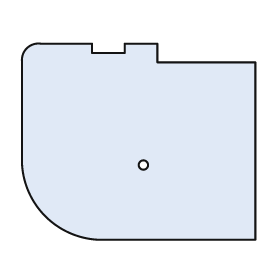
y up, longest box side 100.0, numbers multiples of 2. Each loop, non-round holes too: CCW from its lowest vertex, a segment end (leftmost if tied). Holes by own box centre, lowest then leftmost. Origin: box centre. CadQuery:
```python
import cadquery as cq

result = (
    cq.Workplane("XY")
    .moveTo(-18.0, -42.0)
    .lineTo(50.0, -42.0)
    .lineTo(50.0, 34.0)
    .lineTo(8.0, 34.0)
    .lineTo(8.0, 42.0)
    .lineTo(-6.0, 42.0)
    .lineTo(-6.0, 38.0)
    .lineTo(-20.0, 38.0)
    .lineTo(-20.0, 42.0)
    .lineTo(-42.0, 42.0)
    .threePointArc((-48.0, 40.0), (-50.0, 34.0))
    .lineTo(-50.0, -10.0)
    .threePointArc((-40.0, -32.0), (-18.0, -42.0))
    .close()
    .moveTo(2.0, -10.0)
    .circle(2.0)
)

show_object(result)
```